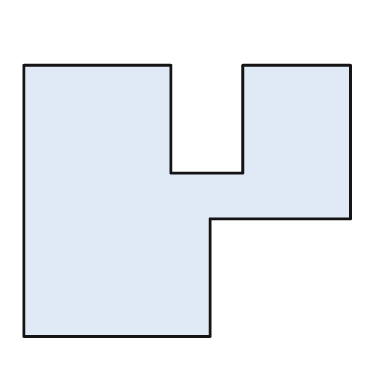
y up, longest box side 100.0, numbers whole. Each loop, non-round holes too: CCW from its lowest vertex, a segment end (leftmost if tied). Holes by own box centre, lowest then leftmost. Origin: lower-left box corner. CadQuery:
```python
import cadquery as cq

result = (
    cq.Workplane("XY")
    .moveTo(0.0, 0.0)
    .lineTo(57.0, 0.0)
    .lineTo(57.0, 36.0)
    .lineTo(100.0, 36.0)
    .lineTo(100.0, 83.0)
    .lineTo(67.0, 83.0)
    .lineTo(67.0, 50.0)
    .lineTo(45.0, 50.0)
    .lineTo(45.0, 83.0)
    .lineTo(0.0, 83.0)
    .close()
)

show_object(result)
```